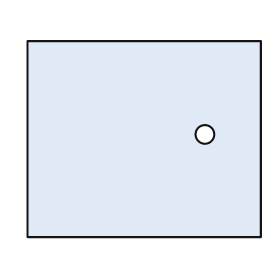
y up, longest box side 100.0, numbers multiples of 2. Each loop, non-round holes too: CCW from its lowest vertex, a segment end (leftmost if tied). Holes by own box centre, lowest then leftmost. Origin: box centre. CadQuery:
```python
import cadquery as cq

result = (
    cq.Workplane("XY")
    .moveTo(-50.0, -42.0)
    .lineTo(50.0, -42.0)
    .lineTo(50.0, 42.0)
    .lineTo(-50.0, 42.0)
    .close()
    .moveTo(26.0, 2.0)
    .circle(4.0)
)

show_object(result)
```